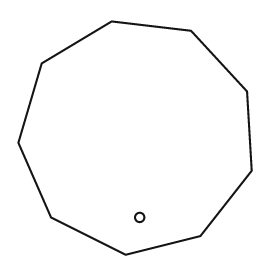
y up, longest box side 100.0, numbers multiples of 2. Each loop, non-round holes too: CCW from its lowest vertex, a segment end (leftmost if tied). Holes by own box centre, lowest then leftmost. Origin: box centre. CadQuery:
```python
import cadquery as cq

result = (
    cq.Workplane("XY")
    .moveTo(-4.0, -50.0)
    .lineTo(28.0, -42.0)
    .lineTo(50.0, -14.0)
    .lineTo(48.0, 20.0)
    .lineTo(24.0, 46.0)
    .lineTo(-10.0, 50.0)
    .lineTo(-40.0, 32.0)
    .lineTo(-50.0, -2.0)
    .lineTo(-36.0, -34.0)
    .close()
    .moveTo(2.0, -34.0)
    .circle(2.0)
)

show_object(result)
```